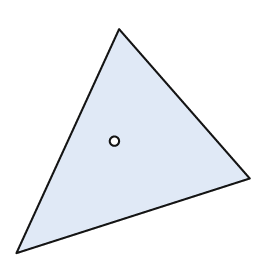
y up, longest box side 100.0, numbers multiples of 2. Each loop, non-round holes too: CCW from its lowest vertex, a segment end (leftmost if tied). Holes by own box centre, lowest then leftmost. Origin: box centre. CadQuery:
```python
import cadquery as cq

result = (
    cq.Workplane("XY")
    .moveTo(-50.0, -48.0)
    .lineTo(50.0, -16.0)
    .lineTo(-6.0, 48.0)
    .close()
    .moveTo(-8.0, 0.0)
    .circle(2.0)
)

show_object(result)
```